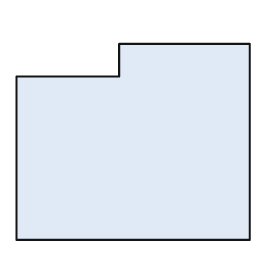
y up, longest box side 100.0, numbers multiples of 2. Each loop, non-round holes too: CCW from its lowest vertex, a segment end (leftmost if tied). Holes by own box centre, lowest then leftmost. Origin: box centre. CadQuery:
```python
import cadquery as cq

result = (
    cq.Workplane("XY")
    .moveTo(-50.0, -42.0)
    .lineTo(50.0, -42.0)
    .lineTo(50.0, 42.0)
    .lineTo(-6.0, 42.0)
    .lineTo(-6.0, 28.0)
    .lineTo(-50.0, 28.0)
    .close()
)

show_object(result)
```